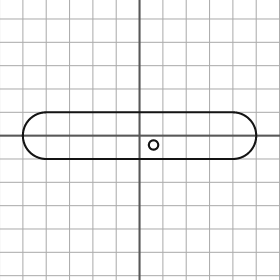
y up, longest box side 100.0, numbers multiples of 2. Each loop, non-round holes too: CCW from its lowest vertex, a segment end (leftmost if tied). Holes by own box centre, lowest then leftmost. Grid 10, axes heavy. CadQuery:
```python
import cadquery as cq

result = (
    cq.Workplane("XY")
    .moveTo(-40.0, -10.0)
    .lineTo(40.0, -10.0)
    .threePointArc((50.0, 0.0), (40.0, 10.0))
    .lineTo(-40.0, 10.0)
    .threePointArc((-50.0, 0.0), (-40.0, -10.0))
    .close()
    .moveTo(6.0, -4.0)
    .circle(2.0)
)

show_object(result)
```